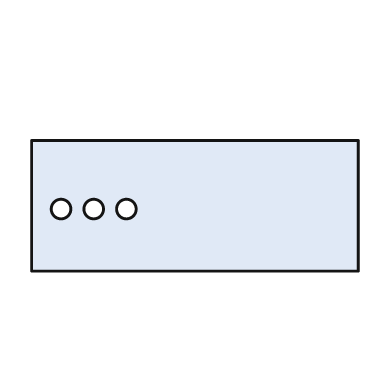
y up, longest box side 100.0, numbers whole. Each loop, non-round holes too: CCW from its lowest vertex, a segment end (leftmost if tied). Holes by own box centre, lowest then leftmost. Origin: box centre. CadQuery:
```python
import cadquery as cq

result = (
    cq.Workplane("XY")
    .moveTo(-50.0, -20.0)
    .lineTo(50.0, -20.0)
    .lineTo(50.0, 20.0)
    .lineTo(-50.0, 20.0)
    .close()
    .moveTo(-41.0, -1.0)
    .circle(3.0)
    .moveTo(-31.0, -1.0)
    .circle(3.0)
    .moveTo(-21.0, -1.0)
    .circle(3.0)
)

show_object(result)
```